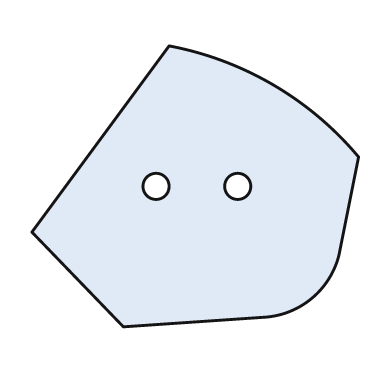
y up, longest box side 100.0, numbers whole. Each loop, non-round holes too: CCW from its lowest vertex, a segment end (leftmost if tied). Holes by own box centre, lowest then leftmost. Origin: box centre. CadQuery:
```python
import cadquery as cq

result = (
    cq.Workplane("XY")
    .moveTo(-22.0, -43.0)
    .lineTo(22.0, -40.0)
    .threePointArc((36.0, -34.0), (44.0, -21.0))
    .lineTo(50.0, 9.0)
    .threePointArc((24.0, 31.0), (-8.0, 43.0))
    .lineTo(-50.0, -14.0)
    .close()
    .moveTo(-12.0, 0.0)
    .circle(4.0)
    .moveTo(13.0, 0.0)
    .circle(4.0)
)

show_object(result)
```